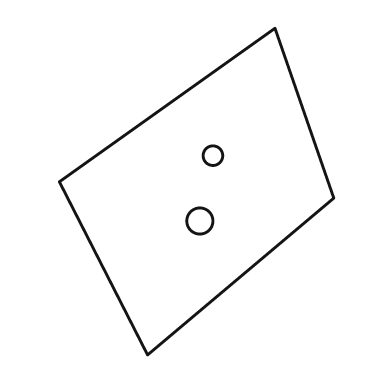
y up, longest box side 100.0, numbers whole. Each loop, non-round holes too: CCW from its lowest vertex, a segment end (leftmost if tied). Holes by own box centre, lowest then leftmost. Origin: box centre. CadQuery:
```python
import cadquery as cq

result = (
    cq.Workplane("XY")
    .moveTo(-15.0, -50.0)
    .lineTo(42.0, -2.0)
    .lineTo(24.0, 50.0)
    .lineTo(-42.0, 3.0)
    .close()
    .moveTo(1.0, -9.0)
    .circle(4.0)
    .moveTo(5.0, 11.0)
    .circle(3.0)
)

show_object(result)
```